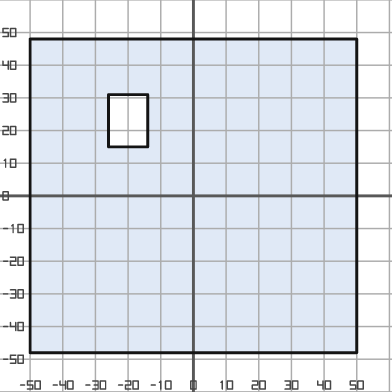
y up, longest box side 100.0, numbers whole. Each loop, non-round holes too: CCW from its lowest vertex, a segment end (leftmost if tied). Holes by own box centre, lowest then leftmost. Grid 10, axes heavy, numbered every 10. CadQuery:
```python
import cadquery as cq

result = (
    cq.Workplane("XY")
    .moveTo(-50.0, -48.0)
    .lineTo(50.0, -48.0)
    .lineTo(50.0, 48.0)
    .lineTo(-50.0, 48.0)
    .close()
    .moveTo(-26.0, 15.0)
    .lineTo(-14.0, 15.0)
    .lineTo(-14.0, 31.0)
    .lineTo(-26.0, 31.0)
    .close()
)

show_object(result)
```